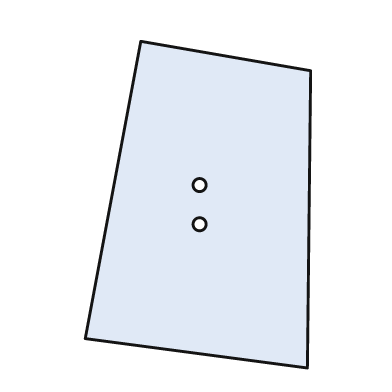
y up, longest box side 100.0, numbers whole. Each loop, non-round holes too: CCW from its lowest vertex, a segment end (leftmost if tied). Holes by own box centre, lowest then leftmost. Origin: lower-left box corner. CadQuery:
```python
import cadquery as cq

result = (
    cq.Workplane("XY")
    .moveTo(68.0, 0.0)
    .lineTo(69.0, 91.0)
    .lineTo(17.0, 100.0)
    .lineTo(0.0, 9.0)
    .close()
    .moveTo(35.0, 44.0)
    .circle(2.0)
    .moveTo(35.0, 56.0)
    .circle(2.0)
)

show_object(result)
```